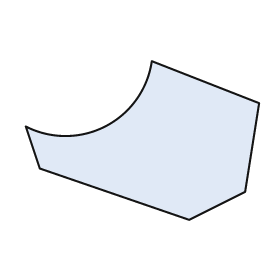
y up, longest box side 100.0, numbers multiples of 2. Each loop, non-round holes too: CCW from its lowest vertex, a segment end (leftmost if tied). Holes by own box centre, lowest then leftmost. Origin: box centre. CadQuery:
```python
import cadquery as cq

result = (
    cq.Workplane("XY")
    .moveTo(20.0, -34.0)
    .lineTo(44.0, -22.0)
    .lineTo(50.0, 16.0)
    .lineTo(4.0, 34.0)
    .threePointArc((-16.0, 6.0), (-50.0, 6.0))
    .lineTo(-44.0, -12.0)
    .close()
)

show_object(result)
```